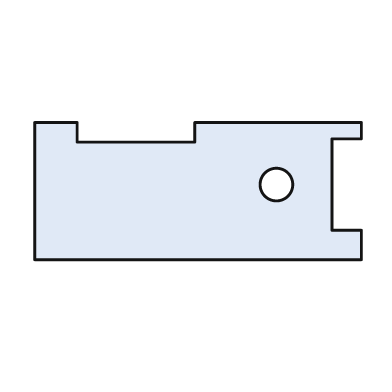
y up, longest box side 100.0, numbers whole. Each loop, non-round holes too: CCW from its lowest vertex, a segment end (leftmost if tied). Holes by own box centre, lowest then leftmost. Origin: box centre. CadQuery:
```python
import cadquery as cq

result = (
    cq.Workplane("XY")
    .moveTo(-50.0, -21.0)
    .lineTo(50.0, -21.0)
    .lineTo(50.0, -12.0)
    .lineTo(41.0, -12.0)
    .lineTo(41.0, 16.0)
    .lineTo(50.0, 16.0)
    .lineTo(50.0, 21.0)
    .lineTo(-1.0, 21.0)
    .lineTo(-1.0, 15.0)
    .lineTo(-37.0, 15.0)
    .lineTo(-37.0, 21.0)
    .lineTo(-50.0, 21.0)
    .close()
    .moveTo(24.0, 2.0)
    .circle(5.0)
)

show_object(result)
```